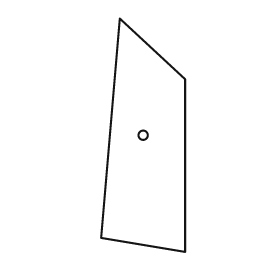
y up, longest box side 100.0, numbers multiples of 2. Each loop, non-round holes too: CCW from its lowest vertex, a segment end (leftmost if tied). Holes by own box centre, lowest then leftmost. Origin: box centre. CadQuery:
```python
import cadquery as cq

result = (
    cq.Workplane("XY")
    .moveTo(18.0, -50.0)
    .lineTo(18.0, 24.0)
    .lineTo(-10.0, 50.0)
    .lineTo(-18.0, -44.0)
    .close()
    .moveTo(0.0, 0.0)
    .circle(2.0)
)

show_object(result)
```